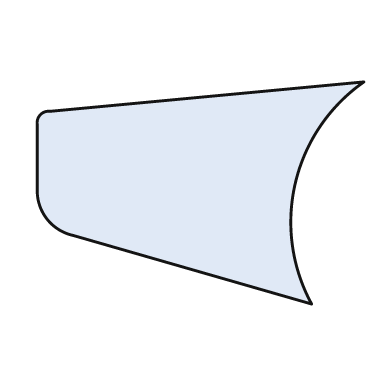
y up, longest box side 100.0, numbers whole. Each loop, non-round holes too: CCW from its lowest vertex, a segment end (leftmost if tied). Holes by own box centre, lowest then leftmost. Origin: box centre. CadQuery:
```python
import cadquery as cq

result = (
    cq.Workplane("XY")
    .moveTo(34.0, -34.0)
    .threePointArc((29.0, 3.0), (50.0, 34.0))
    .lineTo(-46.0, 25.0)
    .threePointArc((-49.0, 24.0), (-50.0, 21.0))
    .lineTo(-50.0, 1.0)
    .threePointArc((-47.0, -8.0), (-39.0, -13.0))
    .close()
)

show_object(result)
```